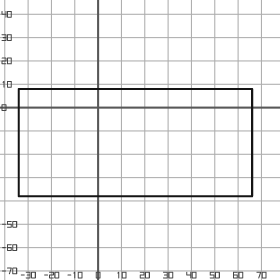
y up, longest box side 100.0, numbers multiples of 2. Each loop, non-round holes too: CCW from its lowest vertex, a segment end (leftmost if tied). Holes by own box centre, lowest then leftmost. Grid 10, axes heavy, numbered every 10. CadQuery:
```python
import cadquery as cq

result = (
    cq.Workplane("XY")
    .moveTo(-34.0, -38.0)
    .lineTo(66.0, -38.0)
    .lineTo(66.0, 8.0)
    .lineTo(-34.0, 8.0)
    .close()
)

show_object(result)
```